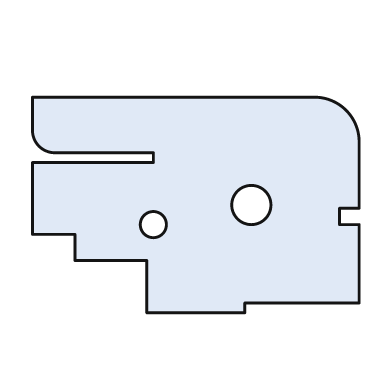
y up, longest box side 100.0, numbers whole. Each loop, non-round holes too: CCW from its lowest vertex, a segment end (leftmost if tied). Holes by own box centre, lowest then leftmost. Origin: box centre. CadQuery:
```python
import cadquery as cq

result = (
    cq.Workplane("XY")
    .moveTo(-15.0, -33.0)
    .lineTo(15.0, -33.0)
    .lineTo(15.0, -30.0)
    .lineTo(50.0, -30.0)
    .lineTo(50.0, -6.0)
    .lineTo(44.0, -6.0)
    .lineTo(44.0, -1.0)
    .lineTo(50.0, -1.0)
    .lineTo(50.0, 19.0)
    .threePointArc((46.0, 29.0), (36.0, 33.0))
    .lineTo(-50.0, 33.0)
    .lineTo(-50.0, 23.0)
    .threePointArc((-48.0, 18.0), (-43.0, 16.0))
    .lineTo(-13.0, 16.0)
    .lineTo(-13.0, 13.0)
    .lineTo(-50.0, 13.0)
    .lineTo(-50.0, -9.0)
    .lineTo(-37.0, -9.0)
    .lineTo(-37.0, -17.0)
    .lineTo(-15.0, -17.0)
    .close()
    .moveTo(-13.0, -6.0)
    .circle(4.0)
    .moveTo(17.0, 0.0)
    .circle(6.0)
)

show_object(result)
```